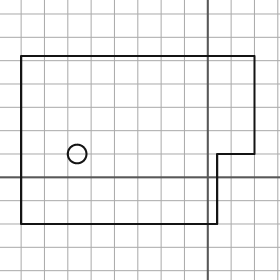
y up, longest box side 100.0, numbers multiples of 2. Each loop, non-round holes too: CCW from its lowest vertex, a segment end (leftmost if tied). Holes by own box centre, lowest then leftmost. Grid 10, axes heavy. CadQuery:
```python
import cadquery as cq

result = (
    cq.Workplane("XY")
    .moveTo(-80.0, -20.0)
    .lineTo(4.0, -20.0)
    .lineTo(4.0, 10.0)
    .lineTo(20.0, 10.0)
    .lineTo(20.0, 52.0)
    .lineTo(-80.0, 52.0)
    .close()
    .moveTo(-56.0, 10.0)
    .circle(4.0)
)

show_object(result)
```